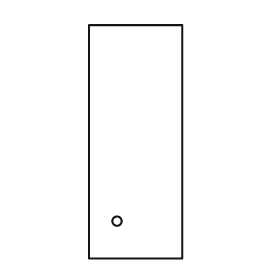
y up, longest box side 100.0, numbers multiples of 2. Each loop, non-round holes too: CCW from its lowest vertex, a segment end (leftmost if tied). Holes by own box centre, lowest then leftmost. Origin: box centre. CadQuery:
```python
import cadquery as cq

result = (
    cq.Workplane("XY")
    .moveTo(-20.0, -50.0)
    .lineTo(20.0, -50.0)
    .lineTo(20.0, 50.0)
    .lineTo(-20.0, 50.0)
    .close()
    .moveTo(-8.0, -34.0)
    .circle(2.0)
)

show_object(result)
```